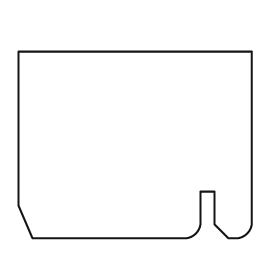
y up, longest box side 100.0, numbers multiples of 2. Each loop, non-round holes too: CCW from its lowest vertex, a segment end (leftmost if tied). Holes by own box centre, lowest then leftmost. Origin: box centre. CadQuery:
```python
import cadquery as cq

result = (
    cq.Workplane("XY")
    .moveTo(-44.0, -40.0)
    .lineTo(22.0, -40.0)
    .threePointArc((26.0, -38.0), (28.0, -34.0))
    .lineTo(28.0, -20.0)
    .lineTo(34.0, -20.0)
    .lineTo(34.0, -34.0)
    .lineTo(40.0, -40.0)
    .lineTo(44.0, -40.0)
    .threePointArc((48.0, -38.0), (50.0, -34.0))
    .lineTo(50.0, 40.0)
    .lineTo(-50.0, 40.0)
    .lineTo(-50.0, -26.0)
    .close()
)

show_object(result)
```